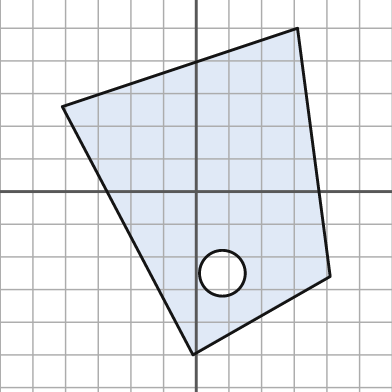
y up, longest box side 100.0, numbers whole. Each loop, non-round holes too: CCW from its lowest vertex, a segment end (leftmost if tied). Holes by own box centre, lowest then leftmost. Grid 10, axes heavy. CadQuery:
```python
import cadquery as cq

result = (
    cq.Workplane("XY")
    .moveTo(-1.0, -50.0)
    .lineTo(41.0, -26.0)
    .lineTo(31.0, 50.0)
    .lineTo(-41.0, 26.0)
    .close()
    .moveTo(8.0, -25.0)
    .circle(7.0)
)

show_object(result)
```